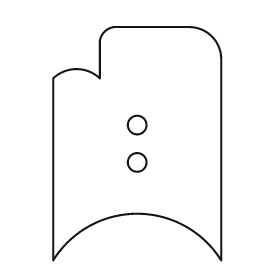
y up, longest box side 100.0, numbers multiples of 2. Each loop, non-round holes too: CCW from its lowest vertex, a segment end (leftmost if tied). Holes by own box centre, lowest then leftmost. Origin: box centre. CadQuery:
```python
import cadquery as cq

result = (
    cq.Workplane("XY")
    .moveTo(-36.0, -50.0)
    .threePointArc((0.0, -30.0), (36.0, -50.0))
    .lineTo(36.0, 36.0)
    .threePointArc((32.0, 46.0), (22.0, 50.0))
    .lineTo(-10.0, 50.0)
    .threePointArc((-14.0, 48.0), (-16.0, 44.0))
    .lineTo(-16.0, 28.0)
    .threePointArc((-26.0, 32.0), (-36.0, 28.0))
    .close()
    .moveTo(0.0, -8.0)
    .circle(4.0)
    .moveTo(0.0, 8.0)
    .circle(4.0)
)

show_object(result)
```